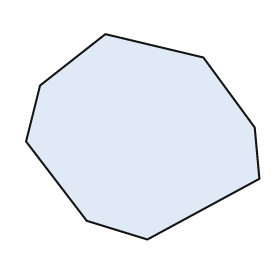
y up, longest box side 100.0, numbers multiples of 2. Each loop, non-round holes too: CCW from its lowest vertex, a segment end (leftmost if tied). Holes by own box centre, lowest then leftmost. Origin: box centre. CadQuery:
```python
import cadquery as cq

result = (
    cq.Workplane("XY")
    .moveTo(2.0, -44.0)
    .lineTo(50.0, -18.0)
    .lineTo(48.0, 4.0)
    .lineTo(26.0, 34.0)
    .lineTo(-16.0, 44.0)
    .lineTo(-44.0, 22.0)
    .lineTo(-50.0, -2.0)
    .lineTo(-24.0, -36.0)
    .close()
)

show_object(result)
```